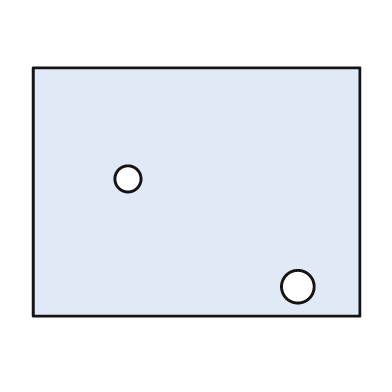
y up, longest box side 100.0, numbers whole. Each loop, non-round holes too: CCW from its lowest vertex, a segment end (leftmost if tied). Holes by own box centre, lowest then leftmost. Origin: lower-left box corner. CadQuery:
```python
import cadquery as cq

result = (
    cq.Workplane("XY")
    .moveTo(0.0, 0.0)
    .lineTo(100.0, 0.0)
    .lineTo(100.0, 76.0)
    .lineTo(0.0, 76.0)
    .close()
    .moveTo(81.0, 9.0)
    .circle(5.0)
    .moveTo(29.0, 42.0)
    .circle(4.0)
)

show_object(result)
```